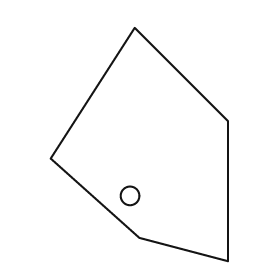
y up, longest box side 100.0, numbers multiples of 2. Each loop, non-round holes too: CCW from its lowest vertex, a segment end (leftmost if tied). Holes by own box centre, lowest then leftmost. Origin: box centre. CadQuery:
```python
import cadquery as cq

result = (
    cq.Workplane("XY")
    .moveTo(38.0, -50.0)
    .lineTo(38.0, 10.0)
    .lineTo(-2.0, 50.0)
    .lineTo(-38.0, -6.0)
    .lineTo(0.0, -40.0)
    .close()
    .moveTo(-4.0, -22.0)
    .circle(4.0)
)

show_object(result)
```